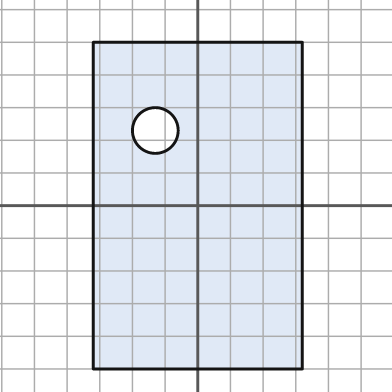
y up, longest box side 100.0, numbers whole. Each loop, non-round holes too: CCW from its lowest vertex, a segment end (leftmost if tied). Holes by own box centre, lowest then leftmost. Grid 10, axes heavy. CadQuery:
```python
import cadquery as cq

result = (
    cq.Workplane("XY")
    .moveTo(-32.0, -50.0)
    .lineTo(32.0, -50.0)
    .lineTo(32.0, 50.0)
    .lineTo(-32.0, 50.0)
    .close()
    .moveTo(-13.0, 23.0)
    .circle(7.0)
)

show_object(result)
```